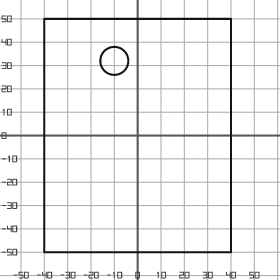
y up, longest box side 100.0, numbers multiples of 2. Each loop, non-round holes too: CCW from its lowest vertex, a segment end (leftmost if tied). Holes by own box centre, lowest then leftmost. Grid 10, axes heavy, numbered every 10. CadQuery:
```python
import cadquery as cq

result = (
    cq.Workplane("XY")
    .moveTo(-40.0, -50.0)
    .lineTo(40.0, -50.0)
    .lineTo(40.0, 50.0)
    .lineTo(-40.0, 50.0)
    .close()
    .moveTo(-10.0, 32.0)
    .circle(6.0)
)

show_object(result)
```